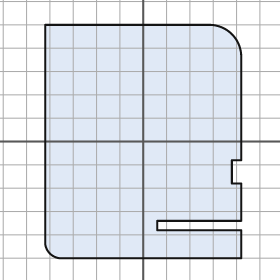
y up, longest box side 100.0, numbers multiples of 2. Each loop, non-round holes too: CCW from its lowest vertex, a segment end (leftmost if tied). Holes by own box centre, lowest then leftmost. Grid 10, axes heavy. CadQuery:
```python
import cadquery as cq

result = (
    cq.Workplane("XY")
    .moveTo(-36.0, -50.0)
    .lineTo(42.0, -50.0)
    .lineTo(42.0, -38.0)
    .lineTo(6.0, -38.0)
    .lineTo(6.0, -34.0)
    .lineTo(42.0, -34.0)
    .lineTo(42.0, -18.0)
    .lineTo(38.0, -18.0)
    .lineTo(38.0, -8.0)
    .lineTo(42.0, -8.0)
    .lineTo(42.0, 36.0)
    .threePointArc((38.0, 46.0), (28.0, 50.0))
    .lineTo(-42.0, 50.0)
    .lineTo(-42.0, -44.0)
    .threePointArc((-40.0, -48.0), (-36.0, -50.0))
    .close()
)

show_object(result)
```